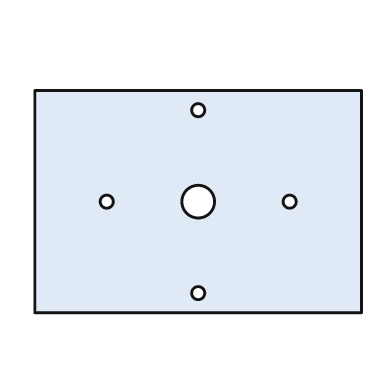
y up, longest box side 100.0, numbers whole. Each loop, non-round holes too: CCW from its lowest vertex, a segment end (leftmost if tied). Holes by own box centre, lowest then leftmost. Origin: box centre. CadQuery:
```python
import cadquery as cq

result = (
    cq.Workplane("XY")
    .moveTo(-50.0, -34.0)
    .lineTo(50.0, -34.0)
    .lineTo(50.0, 34.0)
    .lineTo(-50.0, 34.0)
    .close()
    .moveTo(0.0, -28.0)
    .circle(2.0)
    .moveTo(-28.0, 0.0)
    .circle(2.0)
    .moveTo(0.0, 0.0)
    .circle(5.0)
    .moveTo(28.0, 0.0)
    .circle(2.0)
    .moveTo(0.0, 28.0)
    .circle(2.0)
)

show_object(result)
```